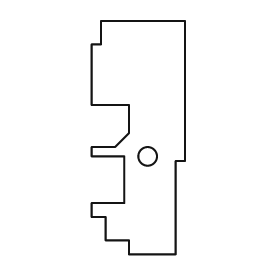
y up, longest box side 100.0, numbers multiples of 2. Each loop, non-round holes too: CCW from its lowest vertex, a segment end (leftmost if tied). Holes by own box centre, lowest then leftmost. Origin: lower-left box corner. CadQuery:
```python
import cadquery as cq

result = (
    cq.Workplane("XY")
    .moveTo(16.0, 0.0)
    .lineTo(36.0, 0.0)
    .lineTo(36.0, 40.0)
    .lineTo(40.0, 40.0)
    .lineTo(40.0, 100.0)
    .lineTo(4.0, 100.0)
    .lineTo(4.0, 90.0)
    .lineTo(0.0, 90.0)
    .lineTo(0.0, 64.0)
    .lineTo(16.0, 64.0)
    .lineTo(16.0, 52.0)
    .lineTo(10.0, 46.0)
    .lineTo(0.0, 46.0)
    .lineTo(0.0, 42.0)
    .lineTo(14.0, 42.0)
    .lineTo(14.0, 22.0)
    .lineTo(0.0, 22.0)
    .lineTo(0.0, 16.0)
    .lineTo(6.0, 16.0)
    .lineTo(6.0, 6.0)
    .lineTo(16.0, 6.0)
    .close()
    .moveTo(24.0, 42.0)
    .circle(4.0)
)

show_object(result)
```